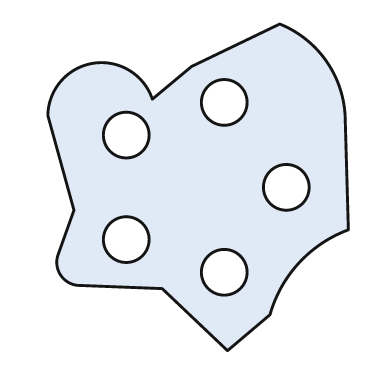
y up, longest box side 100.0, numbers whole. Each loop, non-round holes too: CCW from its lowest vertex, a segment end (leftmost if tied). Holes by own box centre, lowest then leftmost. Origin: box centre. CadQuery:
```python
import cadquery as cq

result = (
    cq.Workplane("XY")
    .moveTo(9.0, -50.0)
    .lineTo(22.0, -39.0)
    .threePointArc((31.0, -23.0), (46.0, -13.0))
    .lineTo(45.0, 22.0)
    .threePointArc((39.0, 39.0), (25.0, 50.0))
    .lineTo(-2.0, 37.0)
    .lineTo(-14.0, 27.0)
    .threePointArc((-32.0, 38.0), (-46.0, 22.0))
    .lineTo(-38.0, -7.0)
    .lineTo(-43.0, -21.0)
    .threePointArc((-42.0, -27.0), (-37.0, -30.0))
    .lineTo(-11.0, -31.0)
    .close()
    .moveTo(8.0, -26.0)
    .circle(7.0)
    .moveTo(-22.0, -16.0)
    .circle(7.0)
    .moveTo(27.0, 0.0)
    .circle(7.0)
    .moveTo(-22.0, 16.0)
    .circle(7.0)
    .moveTo(8.0, 26.0)
    .circle(7.0)
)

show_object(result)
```